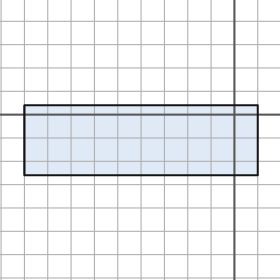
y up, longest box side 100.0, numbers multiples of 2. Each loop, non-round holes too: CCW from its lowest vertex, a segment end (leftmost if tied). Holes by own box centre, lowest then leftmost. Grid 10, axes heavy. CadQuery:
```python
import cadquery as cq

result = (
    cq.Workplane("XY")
    .moveTo(-90.0, -26.0)
    .lineTo(10.0, -26.0)
    .lineTo(10.0, 4.0)
    .lineTo(-90.0, 4.0)
    .close()
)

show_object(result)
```